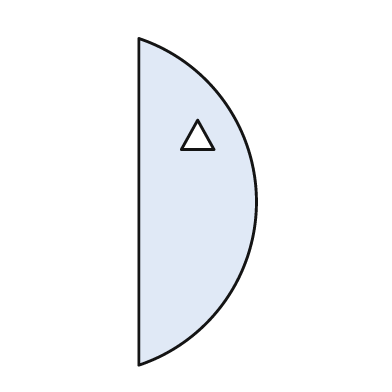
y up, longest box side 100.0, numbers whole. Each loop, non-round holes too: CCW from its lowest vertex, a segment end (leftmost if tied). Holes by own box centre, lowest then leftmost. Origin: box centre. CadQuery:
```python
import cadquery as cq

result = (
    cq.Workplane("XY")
    .moveTo(-18.0, -50.0)
    .threePointArc((18.0, 0.0), (-18.0, 50.0))
    .close()
    .moveTo(-5.0, 16.0)
    .lineTo(5.0, 16.0)
    .lineTo(0.0, 25.0)
    .close()
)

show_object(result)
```